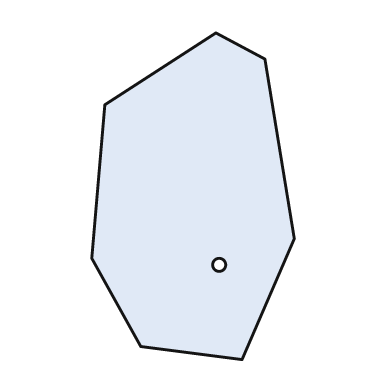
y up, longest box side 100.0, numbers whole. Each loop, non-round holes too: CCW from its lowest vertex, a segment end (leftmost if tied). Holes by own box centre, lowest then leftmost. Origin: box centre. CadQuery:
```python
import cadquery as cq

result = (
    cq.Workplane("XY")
    .moveTo(15.0, -50.0)
    .lineTo(31.0, -13.0)
    .lineTo(22.0, 42.0)
    .lineTo(7.0, 50.0)
    .lineTo(-27.0, 28.0)
    .lineTo(-31.0, -19.0)
    .lineTo(-16.0, -46.0)
    .close()
    .moveTo(8.0, -21.0)
    .circle(2.0)
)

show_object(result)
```